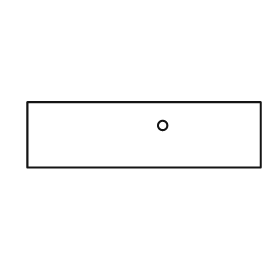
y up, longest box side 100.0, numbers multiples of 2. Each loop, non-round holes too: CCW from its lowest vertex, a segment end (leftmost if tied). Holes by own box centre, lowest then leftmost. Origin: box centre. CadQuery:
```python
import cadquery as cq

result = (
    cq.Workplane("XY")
    .moveTo(-50.0, -14.0)
    .lineTo(50.0, -14.0)
    .lineTo(50.0, 14.0)
    .lineTo(-50.0, 14.0)
    .close()
    .moveTo(8.0, 4.0)
    .circle(2.0)
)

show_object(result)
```